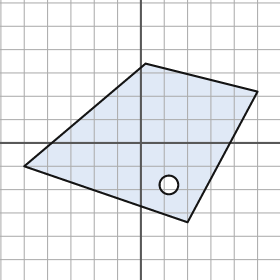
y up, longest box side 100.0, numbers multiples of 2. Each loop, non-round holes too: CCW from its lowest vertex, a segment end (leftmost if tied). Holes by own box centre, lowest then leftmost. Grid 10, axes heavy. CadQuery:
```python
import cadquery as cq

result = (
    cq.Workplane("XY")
    .moveTo(20.0, -34.0)
    .lineTo(50.0, 22.0)
    .lineTo(2.0, 34.0)
    .lineTo(-50.0, -10.0)
    .close()
    .moveTo(12.0, -18.0)
    .circle(4.0)
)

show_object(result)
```